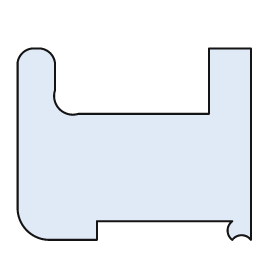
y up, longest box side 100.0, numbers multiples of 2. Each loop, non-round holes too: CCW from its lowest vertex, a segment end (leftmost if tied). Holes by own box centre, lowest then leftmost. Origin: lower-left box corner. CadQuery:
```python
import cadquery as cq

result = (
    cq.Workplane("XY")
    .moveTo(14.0, 0.0)
    .lineTo(34.0, 0.0)
    .lineTo(34.0, 8.0)
    .lineTo(92.0, 8.0)
    .threePointArc((90.0, 4.0), (92.0, 0.0))
    .threePointArc((96.0, 2.0), (100.0, 0.0))
    .lineTo(100.0, 82.0)
    .lineTo(82.0, 82.0)
    .lineTo(82.0, 54.0)
    .lineTo(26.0, 54.0)
    .threePointArc((18.0, 56.0), (16.0, 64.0))
    .lineTo(16.0, 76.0)
    .threePointArc((14.0, 80.0), (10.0, 82.0))
    .lineTo(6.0, 82.0)
    .threePointArc((2.0, 80.0), (0.0, 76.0))
    .lineTo(0.0, 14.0)
    .threePointArc((4.0, 4.0), (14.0, 0.0))
    .close()
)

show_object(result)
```